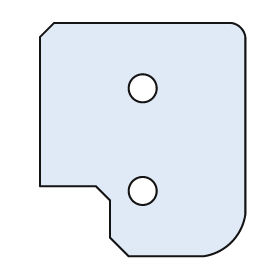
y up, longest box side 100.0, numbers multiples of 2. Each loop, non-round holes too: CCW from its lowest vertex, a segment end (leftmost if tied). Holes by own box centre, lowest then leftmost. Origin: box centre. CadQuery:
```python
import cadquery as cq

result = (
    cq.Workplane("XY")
    .moveTo(-6.0, -50.0)
    .lineTo(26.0, -50.0)
    .threePointArc((38.0, -44.0), (44.0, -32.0))
    .lineTo(44.0, 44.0)
    .threePointArc((42.0, 48.0), (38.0, 50.0))
    .lineTo(-38.0, 50.0)
    .lineTo(-44.0, 44.0)
    .lineTo(-44.0, -20.0)
    .lineTo(-20.0, -20.0)
    .lineTo(-14.0, -26.0)
    .lineTo(-14.0, -42.0)
    .close()
    .moveTo(0.0, -22.0)
    .circle(6.0)
    .moveTo(0.0, 22.0)
    .circle(6.0)
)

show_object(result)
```